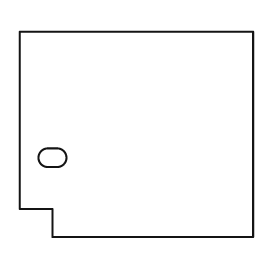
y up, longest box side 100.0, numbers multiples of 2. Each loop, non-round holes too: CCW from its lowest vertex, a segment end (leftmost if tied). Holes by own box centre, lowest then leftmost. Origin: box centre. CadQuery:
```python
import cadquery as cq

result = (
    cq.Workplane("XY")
    .moveTo(-36.0, -44.0)
    .lineTo(50.0, -44.0)
    .lineTo(50.0, 44.0)
    .lineTo(-50.0, 44.0)
    .lineTo(-50.0, -32.0)
    .lineTo(-36.0, -32.0)
    .close()
    .moveTo(-38.0, -14.0)
    .lineTo(-34.0, -14.0)
    .threePointArc((-30.0, -10.0), (-34.0, -6.0))
    .lineTo(-38.0, -6.0)
    .threePointArc((-42.0, -10.0), (-38.0, -14.0))
    .close()
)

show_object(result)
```